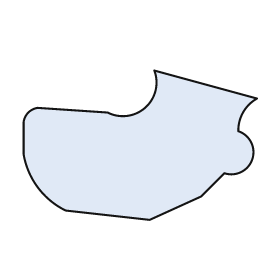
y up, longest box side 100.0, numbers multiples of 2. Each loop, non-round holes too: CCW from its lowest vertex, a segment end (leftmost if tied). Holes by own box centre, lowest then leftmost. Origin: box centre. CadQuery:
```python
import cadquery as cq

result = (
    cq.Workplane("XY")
    .moveTo(4.0, -32.0)
    .lineTo(26.0, -22.0)
    .lineTo(36.0, -12.0)
    .threePointArc((48.0, -6.0), (42.0, 6.0))
    .threePointArc((44.0, 14.0), (50.0, 20.0))
    .lineTo(6.0, 32.0)
    .threePointArc((2.0, 16.0), (-14.0, 14.0))
    .lineTo(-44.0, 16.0)
    .threePointArc((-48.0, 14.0), (-50.0, 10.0))
    .lineTo(-50.0, -4.0)
    .threePointArc((-44.0, -18.0), (-32.0, -28.0))
    .close()
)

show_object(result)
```